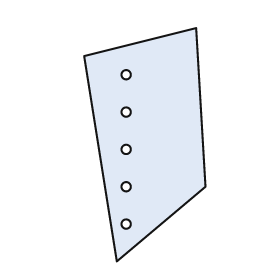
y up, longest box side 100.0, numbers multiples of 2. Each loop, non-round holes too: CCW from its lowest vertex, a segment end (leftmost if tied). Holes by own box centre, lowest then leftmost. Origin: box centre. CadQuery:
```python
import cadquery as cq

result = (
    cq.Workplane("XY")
    .moveTo(-12.0, -50.0)
    .lineTo(26.0, -18.0)
    .lineTo(22.0, 50.0)
    .lineTo(-26.0, 38.0)
    .close()
    .moveTo(-8.0, -34.0)
    .circle(2.0)
    .moveTo(-8.0, -18.0)
    .circle(2.0)
    .moveTo(-8.0, -2.0)
    .circle(2.0)
    .moveTo(-8.0, 14.0)
    .circle(2.0)
    .moveTo(-8.0, 30.0)
    .circle(2.0)
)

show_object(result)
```